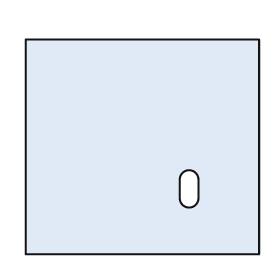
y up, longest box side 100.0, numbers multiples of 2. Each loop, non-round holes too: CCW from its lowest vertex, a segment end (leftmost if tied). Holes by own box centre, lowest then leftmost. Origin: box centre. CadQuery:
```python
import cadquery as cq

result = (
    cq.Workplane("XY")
    .moveTo(-50.0, -46.0)
    .lineTo(50.0, -46.0)
    .lineTo(50.0, 46.0)
    .lineTo(-50.0, 46.0)
    .close()
    .moveTo(16.0, -22.0)
    .threePointArc((20.0, -26.0), (24.0, -22.0))
    .lineTo(24.0, -14.0)
    .threePointArc((20.0, -10.0), (16.0, -14.0))
    .close()
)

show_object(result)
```